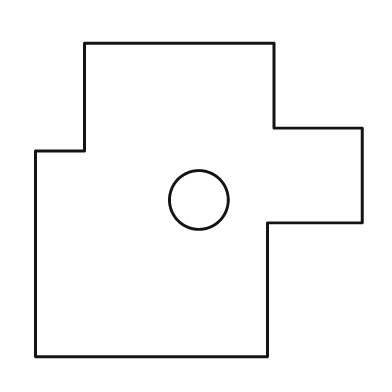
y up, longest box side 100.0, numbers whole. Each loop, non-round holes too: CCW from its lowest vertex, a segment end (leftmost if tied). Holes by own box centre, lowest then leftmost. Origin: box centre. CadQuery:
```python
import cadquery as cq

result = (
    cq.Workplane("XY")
    .moveTo(-50.0, -48.0)
    .lineTo(21.0, -48.0)
    .lineTo(21.0, -7.0)
    .lineTo(50.0, -7.0)
    .lineTo(50.0, 22.0)
    .lineTo(23.0, 22.0)
    .lineTo(23.0, 48.0)
    .lineTo(-35.0, 48.0)
    .lineTo(-35.0, 15.0)
    .lineTo(-50.0, 15.0)
    .close()
    .moveTo(0.0, 0.0)
    .circle(9.0)
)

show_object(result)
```